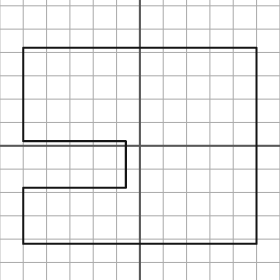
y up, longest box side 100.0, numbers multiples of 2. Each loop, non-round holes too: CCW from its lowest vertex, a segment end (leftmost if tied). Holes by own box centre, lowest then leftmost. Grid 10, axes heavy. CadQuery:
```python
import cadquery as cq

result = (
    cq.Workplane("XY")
    .moveTo(-50.0, -42.0)
    .lineTo(50.0, -42.0)
    .lineTo(50.0, 42.0)
    .lineTo(-50.0, 42.0)
    .lineTo(-50.0, 2.0)
    .lineTo(-6.0, 2.0)
    .lineTo(-6.0, -18.0)
    .lineTo(-50.0, -18.0)
    .close()
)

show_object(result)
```